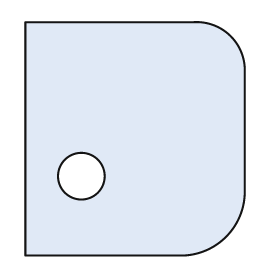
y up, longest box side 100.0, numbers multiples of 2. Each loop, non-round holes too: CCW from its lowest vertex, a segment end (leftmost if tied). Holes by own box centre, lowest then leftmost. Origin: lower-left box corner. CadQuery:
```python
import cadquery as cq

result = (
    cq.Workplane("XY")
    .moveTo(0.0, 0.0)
    .lineTo(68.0, 0.0)
    .threePointArc((86.0, 8.0), (94.0, 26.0))
    .lineTo(94.0, 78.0)
    .threePointArc((88.0, 94.0), (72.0, 100.0))
    .lineTo(0.0, 100.0)
    .close()
    .moveTo(24.0, 34.0)
    .circle(10.0)
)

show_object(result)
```